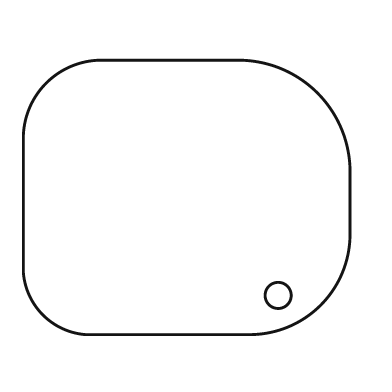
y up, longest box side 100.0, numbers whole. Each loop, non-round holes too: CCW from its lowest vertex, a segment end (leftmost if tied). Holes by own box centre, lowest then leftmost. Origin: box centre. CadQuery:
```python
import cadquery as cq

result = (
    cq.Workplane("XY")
    .moveTo(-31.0, -42.0)
    .lineTo(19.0, -42.0)
    .threePointArc((41.0, -33.0), (50.0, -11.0))
    .lineTo(50.0, 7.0)
    .threePointArc((40.0, 32.0), (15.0, 42.0))
    .lineTo(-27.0, 42.0)
    .threePointArc((-43.0, 35.0), (-50.0, 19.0))
    .lineTo(-50.0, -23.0)
    .threePointArc((-44.0, -36.0), (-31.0, -42.0))
    .close()
    .moveTo(28.0, -30.0)
    .circle(4.0)
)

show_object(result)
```